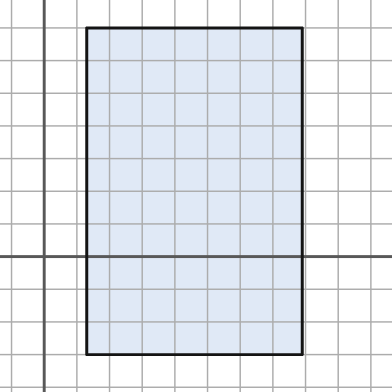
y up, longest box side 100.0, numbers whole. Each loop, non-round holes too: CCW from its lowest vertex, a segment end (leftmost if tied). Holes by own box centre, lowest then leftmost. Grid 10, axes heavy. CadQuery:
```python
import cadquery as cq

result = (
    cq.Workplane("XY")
    .moveTo(13.0, -30.0)
    .lineTo(79.0, -30.0)
    .lineTo(79.0, 70.0)
    .lineTo(13.0, 70.0)
    .close()
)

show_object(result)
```